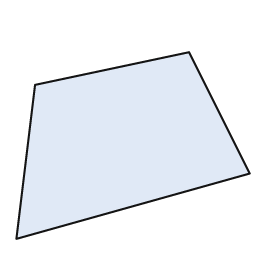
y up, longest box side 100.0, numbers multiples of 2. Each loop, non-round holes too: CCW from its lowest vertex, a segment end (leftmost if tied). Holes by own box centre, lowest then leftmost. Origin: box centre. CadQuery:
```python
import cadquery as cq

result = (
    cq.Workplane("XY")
    .moveTo(-50.0, -40.0)
    .lineTo(50.0, -12.0)
    .lineTo(24.0, 40.0)
    .lineTo(-42.0, 26.0)
    .close()
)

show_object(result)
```